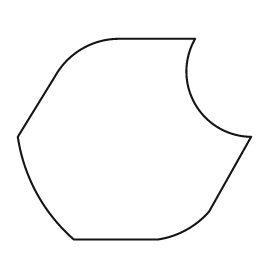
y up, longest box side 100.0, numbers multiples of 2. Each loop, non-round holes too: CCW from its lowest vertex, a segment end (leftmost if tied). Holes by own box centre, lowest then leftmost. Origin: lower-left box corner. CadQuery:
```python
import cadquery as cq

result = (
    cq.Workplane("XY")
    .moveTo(24.0, 0.0)
    .lineTo(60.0, 0.0)
    .threePointArc((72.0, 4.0), (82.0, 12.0))
    .lineTo(100.0, 44.0)
    .threePointArc((76.0, 58.0), (76.0, 86.0))
    .lineTo(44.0, 86.0)
    .threePointArc((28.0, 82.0), (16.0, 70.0))
    .lineTo(0.0, 44.0)
    .threePointArc((8.0, 20.0), (24.0, 0.0))
    .close()
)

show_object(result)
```